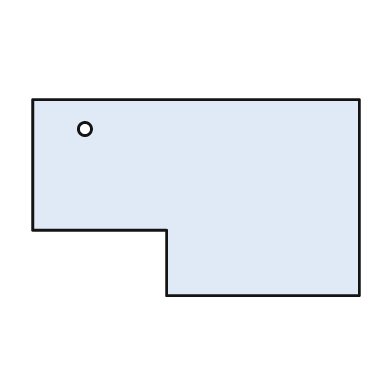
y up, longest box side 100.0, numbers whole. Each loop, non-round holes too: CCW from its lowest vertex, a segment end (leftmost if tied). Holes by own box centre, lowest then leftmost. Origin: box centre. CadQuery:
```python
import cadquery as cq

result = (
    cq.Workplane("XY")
    .moveTo(-9.0, -30.0)
    .lineTo(50.0, -30.0)
    .lineTo(50.0, 30.0)
    .lineTo(-50.0, 30.0)
    .lineTo(-50.0, -10.0)
    .lineTo(-9.0, -10.0)
    .close()
    .moveTo(-34.0, 21.0)
    .circle(2.0)
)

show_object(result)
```